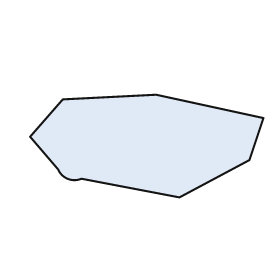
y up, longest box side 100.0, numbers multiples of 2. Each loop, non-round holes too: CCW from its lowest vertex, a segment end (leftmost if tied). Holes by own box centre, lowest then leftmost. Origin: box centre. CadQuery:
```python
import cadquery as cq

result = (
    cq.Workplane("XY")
    .moveTo(14.0, -22.0)
    .lineTo(44.0, -6.0)
    .lineTo(50.0, 12.0)
    .lineTo(4.0, 22.0)
    .lineTo(-36.0, 20.0)
    .lineTo(-50.0, 4.0)
    .lineTo(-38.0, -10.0)
    .threePointArc((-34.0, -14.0), (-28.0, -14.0))
    .close()
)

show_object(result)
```